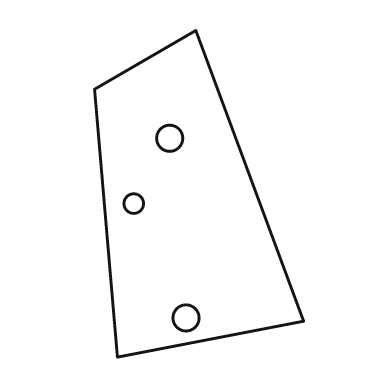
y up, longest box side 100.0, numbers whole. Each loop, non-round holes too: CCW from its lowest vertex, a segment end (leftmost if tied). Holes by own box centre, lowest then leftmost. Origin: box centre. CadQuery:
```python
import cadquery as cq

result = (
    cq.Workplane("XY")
    .moveTo(-25.0, -50.0)
    .lineTo(32.0, -39.0)
    .lineTo(-1.0, 50.0)
    .lineTo(-32.0, 32.0)
    .close()
    .moveTo(-4.0, -38.0)
    .circle(4.0)
    .moveTo(-20.0, -3.0)
    .circle(3.0)
    .moveTo(-9.0, 17.0)
    .circle(4.0)
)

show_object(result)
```